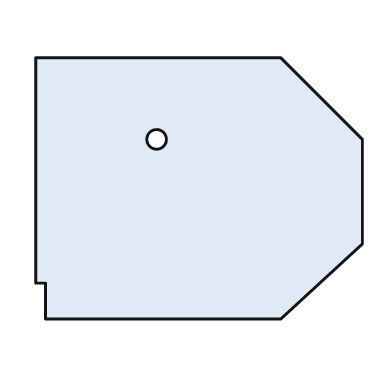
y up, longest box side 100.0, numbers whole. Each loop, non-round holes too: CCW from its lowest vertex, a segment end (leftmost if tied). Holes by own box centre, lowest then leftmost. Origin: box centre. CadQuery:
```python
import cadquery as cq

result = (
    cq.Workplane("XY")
    .moveTo(-47.0, -40.0)
    .lineTo(25.0, -40.0)
    .lineTo(50.0, -17.0)
    .lineTo(50.0, 15.0)
    .lineTo(25.0, 40.0)
    .lineTo(-50.0, 40.0)
    .lineTo(-50.0, -29.0)
    .lineTo(-47.0, -29.0)
    .close()
    .moveTo(-13.0, 15.0)
    .circle(3.0)
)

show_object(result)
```